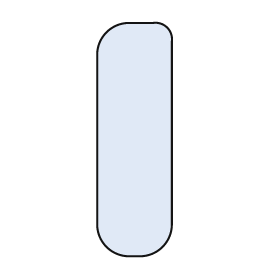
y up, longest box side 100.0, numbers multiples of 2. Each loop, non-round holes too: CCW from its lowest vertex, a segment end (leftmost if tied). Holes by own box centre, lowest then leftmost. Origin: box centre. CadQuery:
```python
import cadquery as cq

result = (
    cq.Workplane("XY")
    .moveTo(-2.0, -50.0)
    .lineTo(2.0, -50.0)
    .threePointArc((12.0, -46.0), (16.0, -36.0))
    .lineTo(16.0, 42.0)
    .threePointArc((14.0, 48.0), (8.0, 50.0))
    .lineTo(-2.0, 50.0)
    .threePointArc((-12.0, 46.0), (-16.0, 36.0))
    .lineTo(-16.0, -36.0)
    .threePointArc((-12.0, -46.0), (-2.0, -50.0))
    .close()
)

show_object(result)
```